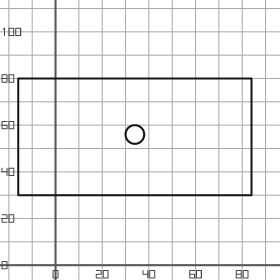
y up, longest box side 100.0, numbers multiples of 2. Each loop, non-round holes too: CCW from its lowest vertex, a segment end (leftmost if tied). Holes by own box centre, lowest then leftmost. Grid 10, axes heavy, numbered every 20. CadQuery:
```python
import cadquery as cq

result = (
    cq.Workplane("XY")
    .moveTo(-16.0, 30.0)
    .lineTo(84.0, 30.0)
    .lineTo(84.0, 80.0)
    .lineTo(-16.0, 80.0)
    .close()
    .moveTo(34.0, 56.0)
    .circle(4.0)
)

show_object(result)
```